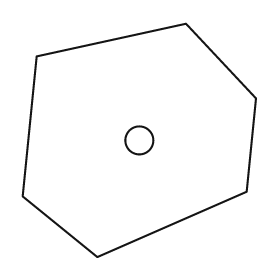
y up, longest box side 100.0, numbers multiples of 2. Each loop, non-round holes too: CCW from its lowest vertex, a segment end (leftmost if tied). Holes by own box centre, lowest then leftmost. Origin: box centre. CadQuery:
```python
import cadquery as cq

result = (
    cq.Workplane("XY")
    .moveTo(-18.0, -50.0)
    .lineTo(46.0, -22.0)
    .lineTo(50.0, 18.0)
    .lineTo(20.0, 50.0)
    .lineTo(-44.0, 36.0)
    .lineTo(-50.0, -24.0)
    .close()
    .moveTo(0.0, 0.0)
    .circle(6.0)
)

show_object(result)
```